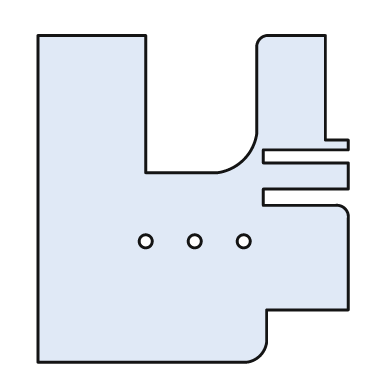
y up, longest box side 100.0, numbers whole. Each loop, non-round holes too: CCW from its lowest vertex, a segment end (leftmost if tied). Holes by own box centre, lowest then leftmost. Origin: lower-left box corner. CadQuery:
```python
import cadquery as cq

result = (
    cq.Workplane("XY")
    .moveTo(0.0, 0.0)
    .lineTo(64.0, 0.0)
    .threePointArc((68.0, 2.0), (70.0, 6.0))
    .lineTo(70.0, 16.0)
    .lineTo(95.0, 16.0)
    .lineTo(95.0, 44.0)
    .threePointArc((94.0, 47.0), (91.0, 48.0))
    .lineTo(69.0, 48.0)
    .lineTo(69.0, 53.0)
    .lineTo(95.0, 53.0)
    .lineTo(95.0, 61.0)
    .lineTo(69.0, 61.0)
    .lineTo(69.0, 65.0)
    .lineTo(95.0, 65.0)
    .lineTo(95.0, 68.0)
    .lineTo(88.0, 68.0)
    .lineTo(88.0, 100.0)
    .lineTo(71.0, 100.0)
    .threePointArc((68.0, 99.0), (67.0, 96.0))
    .lineTo(67.0, 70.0)
    .threePointArc((63.0, 62.0), (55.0, 58.0))
    .lineTo(33.0, 58.0)
    .lineTo(33.0, 100.0)
    .lineTo(0.0, 100.0)
    .close()
    .moveTo(33.0, 37.0)
    .circle(2.0)
    .moveTo(48.0, 37.0)
    .circle(2.0)
    .moveTo(63.0, 37.0)
    .circle(2.0)
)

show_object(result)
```